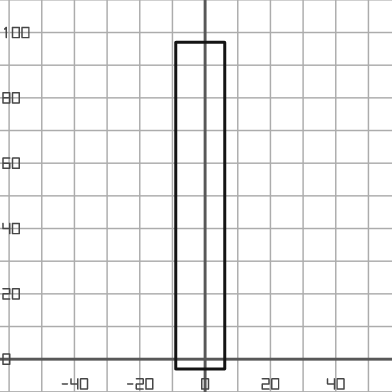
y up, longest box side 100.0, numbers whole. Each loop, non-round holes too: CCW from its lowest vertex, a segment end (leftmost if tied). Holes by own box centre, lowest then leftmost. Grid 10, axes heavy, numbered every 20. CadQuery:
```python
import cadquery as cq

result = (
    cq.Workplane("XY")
    .moveTo(-9.0, -3.0)
    .lineTo(6.0, -3.0)
    .lineTo(6.0, 97.0)
    .lineTo(-9.0, 97.0)
    .close()
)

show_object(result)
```